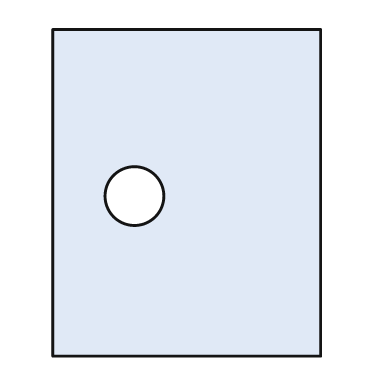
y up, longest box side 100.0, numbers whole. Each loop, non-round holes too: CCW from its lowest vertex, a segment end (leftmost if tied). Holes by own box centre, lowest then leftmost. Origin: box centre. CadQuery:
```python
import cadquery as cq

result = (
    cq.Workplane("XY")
    .moveTo(-41.0, -50.0)
    .lineTo(41.0, -50.0)
    .lineTo(41.0, 50.0)
    .lineTo(-41.0, 50.0)
    .close()
    .moveTo(-16.0, -1.0)
    .circle(9.0)
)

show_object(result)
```